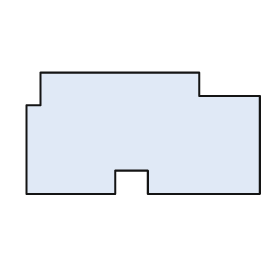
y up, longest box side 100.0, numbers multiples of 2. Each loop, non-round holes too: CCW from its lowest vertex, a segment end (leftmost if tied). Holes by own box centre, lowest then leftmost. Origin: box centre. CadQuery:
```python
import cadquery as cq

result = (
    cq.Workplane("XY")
    .moveTo(-50.0, -26.0)
    .lineTo(-12.0, -26.0)
    .lineTo(-12.0, -16.0)
    .lineTo(2.0, -16.0)
    .lineTo(2.0, -26.0)
    .lineTo(50.0, -26.0)
    .lineTo(50.0, 16.0)
    .lineTo(24.0, 16.0)
    .lineTo(24.0, 26.0)
    .lineTo(-44.0, 26.0)
    .lineTo(-44.0, 12.0)
    .lineTo(-50.0, 12.0)
    .close()
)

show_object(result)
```